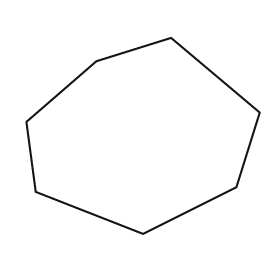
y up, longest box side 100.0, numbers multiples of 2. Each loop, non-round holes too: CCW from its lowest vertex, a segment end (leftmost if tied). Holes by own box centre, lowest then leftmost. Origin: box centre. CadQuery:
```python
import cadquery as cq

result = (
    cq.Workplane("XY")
    .moveTo(0.0, -42.0)
    .lineTo(40.0, -22.0)
    .lineTo(50.0, 10.0)
    .lineTo(12.0, 42.0)
    .lineTo(-20.0, 32.0)
    .lineTo(-50.0, 6.0)
    .lineTo(-46.0, -24.0)
    .close()
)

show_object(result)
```